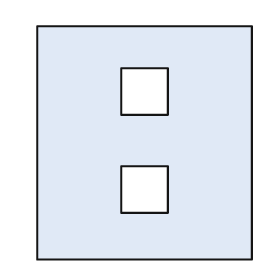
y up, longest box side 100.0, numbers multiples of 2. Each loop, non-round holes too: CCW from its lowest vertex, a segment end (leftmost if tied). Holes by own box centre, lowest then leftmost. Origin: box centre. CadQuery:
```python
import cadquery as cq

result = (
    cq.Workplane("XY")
    .moveTo(-46.0, -50.0)
    .lineTo(46.0, -50.0)
    .lineTo(46.0, 50.0)
    .lineTo(-46.0, 50.0)
    .close()
    .moveTo(-10.0, -30.0)
    .lineTo(10.0, -30.0)
    .lineTo(10.0, -10.0)
    .lineTo(-10.0, -10.0)
    .close()
    .moveTo(-10.0, 12.0)
    .lineTo(10.0, 12.0)
    .lineTo(10.0, 32.0)
    .lineTo(-10.0, 32.0)
    .close()
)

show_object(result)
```